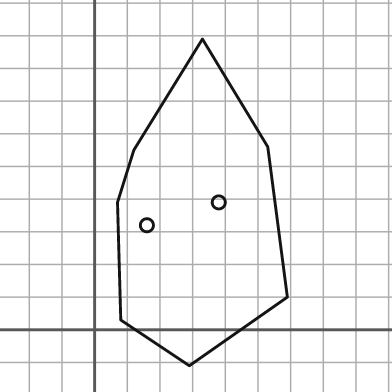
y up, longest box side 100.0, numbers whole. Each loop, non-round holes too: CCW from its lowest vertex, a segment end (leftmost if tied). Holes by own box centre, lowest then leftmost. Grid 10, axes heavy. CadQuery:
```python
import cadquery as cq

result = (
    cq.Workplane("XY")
    .moveTo(29.0, -11.0)
    .lineTo(59.0, 10.0)
    .lineTo(53.0, 56.0)
    .lineTo(33.0, 89.0)
    .lineTo(12.0, 55.0)
    .lineTo(7.0, 39.0)
    .lineTo(8.0, 3.0)
    .close()
    .moveTo(16.0, 32.0)
    .circle(2.0)
    .moveTo(38.0, 39.0)
    .circle(2.0)
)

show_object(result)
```